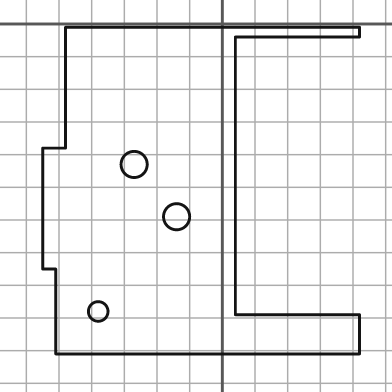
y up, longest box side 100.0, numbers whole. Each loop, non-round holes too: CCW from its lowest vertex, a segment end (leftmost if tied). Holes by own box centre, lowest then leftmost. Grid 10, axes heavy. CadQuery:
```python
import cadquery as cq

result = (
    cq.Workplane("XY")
    .moveTo(-51.0, -101.0)
    .lineTo(42.0, -101.0)
    .lineTo(42.0, -89.0)
    .lineTo(4.0, -89.0)
    .lineTo(4.0, -4.0)
    .lineTo(42.0, -4.0)
    .lineTo(42.0, -1.0)
    .lineTo(-48.0, -1.0)
    .lineTo(-48.0, -38.0)
    .lineTo(-55.0, -38.0)
    .lineTo(-55.0, -75.0)
    .lineTo(-51.0, -75.0)
    .close()
    .moveTo(-38.0, -88.0)
    .circle(3.0)
    .moveTo(-14.0, -59.0)
    .circle(4.0)
    .moveTo(-27.0, -43.0)
    .circle(4.0)
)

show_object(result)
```